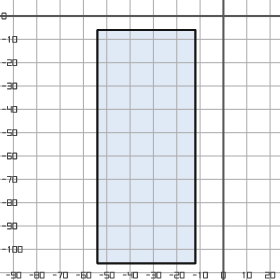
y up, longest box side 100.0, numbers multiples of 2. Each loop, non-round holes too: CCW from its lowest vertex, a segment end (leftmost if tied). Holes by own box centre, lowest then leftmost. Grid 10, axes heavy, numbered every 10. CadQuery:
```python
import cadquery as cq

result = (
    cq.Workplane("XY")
    .moveTo(-54.0, -106.0)
    .lineTo(-12.0, -106.0)
    .lineTo(-12.0, -6.0)
    .lineTo(-54.0, -6.0)
    .close()
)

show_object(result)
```